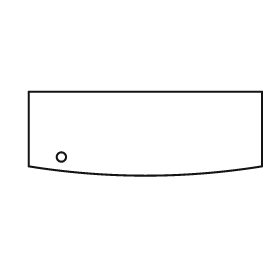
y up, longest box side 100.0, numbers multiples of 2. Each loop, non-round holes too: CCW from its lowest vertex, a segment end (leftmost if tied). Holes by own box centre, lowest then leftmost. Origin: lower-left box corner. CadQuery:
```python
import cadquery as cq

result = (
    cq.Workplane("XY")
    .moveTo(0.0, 4.0)
    .threePointArc((50.0, 0.0), (100.0, 4.0))
    .lineTo(100.0, 36.0)
    .lineTo(0.0, 36.0)
    .close()
    .moveTo(14.0, 8.0)
    .circle(2.0)
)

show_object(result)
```